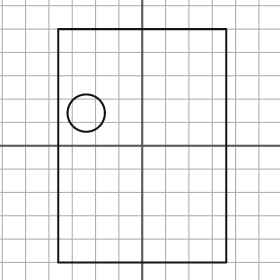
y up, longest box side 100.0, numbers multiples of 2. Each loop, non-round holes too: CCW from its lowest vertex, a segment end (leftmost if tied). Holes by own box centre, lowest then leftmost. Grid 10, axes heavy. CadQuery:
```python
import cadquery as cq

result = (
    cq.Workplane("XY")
    .moveTo(-36.0, -50.0)
    .lineTo(36.0, -50.0)
    .lineTo(36.0, 50.0)
    .lineTo(-36.0, 50.0)
    .close()
    .moveTo(-24.0, 14.0)
    .circle(8.0)
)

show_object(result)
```